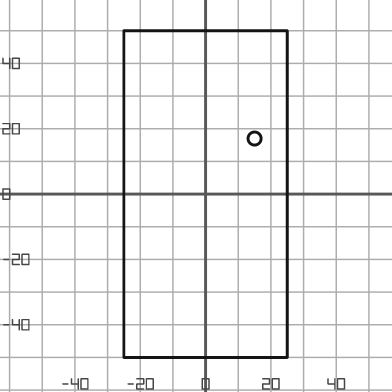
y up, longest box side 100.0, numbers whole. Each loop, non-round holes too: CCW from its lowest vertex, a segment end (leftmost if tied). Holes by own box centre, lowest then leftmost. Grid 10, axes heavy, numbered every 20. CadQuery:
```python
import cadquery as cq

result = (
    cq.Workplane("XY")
    .moveTo(-25.0, -50.0)
    .lineTo(25.0, -50.0)
    .lineTo(25.0, 50.0)
    .lineTo(-25.0, 50.0)
    .close()
    .moveTo(15.0, 17.0)
    .circle(2.0)
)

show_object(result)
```